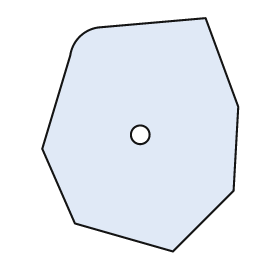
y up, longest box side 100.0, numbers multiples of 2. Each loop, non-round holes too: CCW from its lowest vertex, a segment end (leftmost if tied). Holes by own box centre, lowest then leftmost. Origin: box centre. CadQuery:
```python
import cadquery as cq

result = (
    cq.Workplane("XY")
    .moveTo(14.0, -50.0)
    .lineTo(40.0, -24.0)
    .lineTo(42.0, 12.0)
    .lineTo(28.0, 50.0)
    .lineTo(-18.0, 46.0)
    .threePointArc((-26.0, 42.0), (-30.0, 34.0))
    .lineTo(-42.0, -6.0)
    .lineTo(-28.0, -38.0)
    .close()
    .moveTo(0.0, 0.0)
    .circle(4.0)
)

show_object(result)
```